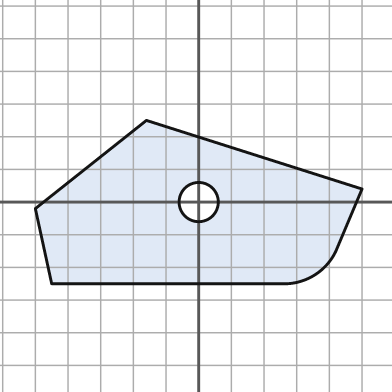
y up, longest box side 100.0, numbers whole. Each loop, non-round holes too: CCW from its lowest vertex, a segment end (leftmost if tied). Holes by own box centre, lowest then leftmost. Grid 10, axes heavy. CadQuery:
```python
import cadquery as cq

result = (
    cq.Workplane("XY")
    .moveTo(-45.0, -25.0)
    .lineTo(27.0, -25.0)
    .threePointArc((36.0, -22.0), (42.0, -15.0))
    .lineTo(50.0, 4.0)
    .lineTo(-16.0, 25.0)
    .lineTo(-50.0, -2.0)
    .close()
    .moveTo(0.0, 0.0)
    .circle(6.0)
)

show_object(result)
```